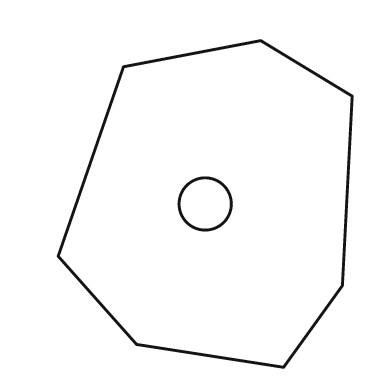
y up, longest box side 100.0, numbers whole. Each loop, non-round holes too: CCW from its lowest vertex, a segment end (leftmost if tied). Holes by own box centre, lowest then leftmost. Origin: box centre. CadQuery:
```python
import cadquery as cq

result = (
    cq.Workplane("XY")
    .moveTo(24.0, -50.0)
    .lineTo(42.0, -25.0)
    .lineTo(45.0, 33.0)
    .lineTo(17.0, 50.0)
    .lineTo(-25.0, 42.0)
    .lineTo(-45.0, -16.0)
    .lineTo(-21.0, -43.0)
    .close()
    .moveTo(0.0, 0.0)
    .circle(8.0)
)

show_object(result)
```